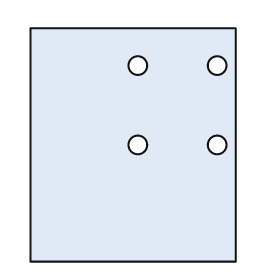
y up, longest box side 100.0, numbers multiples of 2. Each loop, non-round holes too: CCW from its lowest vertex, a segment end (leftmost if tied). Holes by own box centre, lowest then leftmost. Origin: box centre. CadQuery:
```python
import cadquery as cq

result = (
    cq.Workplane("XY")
    .moveTo(-44.0, -50.0)
    .lineTo(44.0, -50.0)
    .lineTo(44.0, 50.0)
    .lineTo(-44.0, 50.0)
    .close()
    .moveTo(2.0, 0.0)
    .circle(4.0)
    .moveTo(36.0, 0.0)
    .circle(4.0)
    .moveTo(2.0, 34.0)
    .circle(4.0)
    .moveTo(36.0, 34.0)
    .circle(4.0)
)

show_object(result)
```